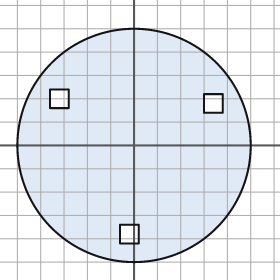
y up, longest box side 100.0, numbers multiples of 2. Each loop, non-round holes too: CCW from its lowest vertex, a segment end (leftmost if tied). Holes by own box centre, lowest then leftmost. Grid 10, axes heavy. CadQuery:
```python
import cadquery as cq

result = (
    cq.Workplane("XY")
    .moveTo(0.0, 0.0)
    .circle(50.0)
    .moveTo(-6.0, -42.0)
    .lineTo(2.0, -42.0)
    .lineTo(2.0, -34.0)
    .lineTo(-6.0, -34.0)
    .close()
    .moveTo(30.0, 14.0)
    .lineTo(38.0, 14.0)
    .lineTo(38.0, 22.0)
    .lineTo(30.0, 22.0)
    .close()
    .moveTo(-36.0, 16.0)
    .lineTo(-28.0, 16.0)
    .lineTo(-28.0, 24.0)
    .lineTo(-36.0, 24.0)
    .close()
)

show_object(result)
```